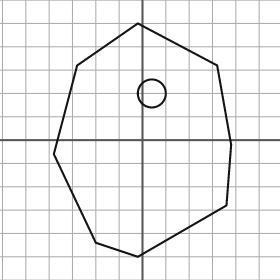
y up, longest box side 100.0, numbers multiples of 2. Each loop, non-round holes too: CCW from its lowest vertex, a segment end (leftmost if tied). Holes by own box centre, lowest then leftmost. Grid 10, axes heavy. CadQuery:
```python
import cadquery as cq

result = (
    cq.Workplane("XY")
    .moveTo(-2.0, -50.0)
    .lineTo(36.0, -28.0)
    .lineTo(38.0, -2.0)
    .lineTo(32.0, 32.0)
    .lineTo(-2.0, 50.0)
    .lineTo(-28.0, 32.0)
    .lineTo(-38.0, -6.0)
    .lineTo(-20.0, -44.0)
    .close()
    .moveTo(4.0, 20.0)
    .circle(6.0)
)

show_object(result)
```